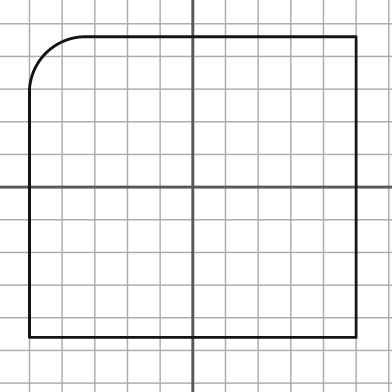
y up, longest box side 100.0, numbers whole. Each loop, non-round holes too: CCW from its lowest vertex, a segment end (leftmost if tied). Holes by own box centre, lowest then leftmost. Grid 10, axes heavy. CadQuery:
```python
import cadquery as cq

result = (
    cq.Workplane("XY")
    .moveTo(-50.0, -46.0)
    .lineTo(50.0, -46.0)
    .lineTo(50.0, 46.0)
    .lineTo(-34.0, 46.0)
    .threePointArc((-45.0, 41.0), (-50.0, 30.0))
    .close()
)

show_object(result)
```